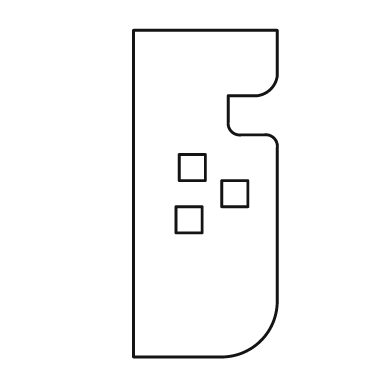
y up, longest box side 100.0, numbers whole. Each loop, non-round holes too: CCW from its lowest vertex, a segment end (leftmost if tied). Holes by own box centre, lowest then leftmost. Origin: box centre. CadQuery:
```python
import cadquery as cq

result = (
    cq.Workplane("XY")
    .moveTo(-22.0, -50.0)
    .lineTo(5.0, -50.0)
    .threePointArc((17.0, -45.0), (22.0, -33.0))
    .lineTo(22.0, 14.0)
    .threePointArc((21.0, 17.0), (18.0, 18.0))
    .lineTo(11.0, 18.0)
    .threePointArc((8.0, 19.0), (7.0, 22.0))
    .lineTo(7.0, 30.0)
    .lineTo(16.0, 30.0)
    .threePointArc((20.0, 32.0), (22.0, 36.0))
    .lineTo(22.0, 50.0)
    .lineTo(-22.0, 50.0)
    .close()
    .moveTo(-9.0, -12.0)
    .lineTo(-1.0, -12.0)
    .lineTo(-1.0, -4.0)
    .lineTo(-9.0, -4.0)
    .close()
    .moveTo(5.0, -4.0)
    .lineTo(13.0, -4.0)
    .lineTo(13.0, 4.0)
    .lineTo(5.0, 4.0)
    .close()
    .moveTo(-8.0, 4.0)
    .lineTo(0.0, 4.0)
    .lineTo(0.0, 12.0)
    .lineTo(-8.0, 12.0)
    .close()
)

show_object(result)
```